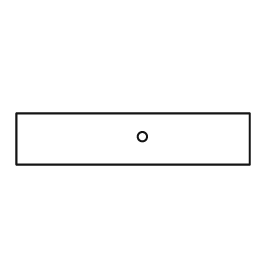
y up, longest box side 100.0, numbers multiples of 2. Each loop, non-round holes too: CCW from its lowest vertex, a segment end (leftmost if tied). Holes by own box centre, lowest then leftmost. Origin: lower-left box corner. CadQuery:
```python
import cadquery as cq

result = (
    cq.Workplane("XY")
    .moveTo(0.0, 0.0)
    .lineTo(100.0, 0.0)
    .lineTo(100.0, 22.0)
    .lineTo(0.0, 22.0)
    .close()
    .moveTo(54.0, 12.0)
    .circle(2.0)
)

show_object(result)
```